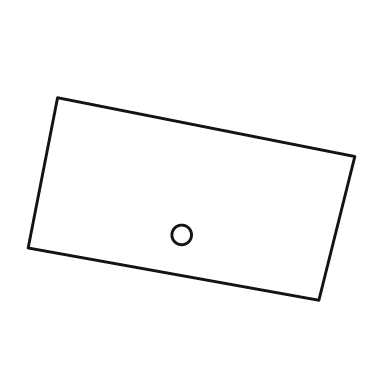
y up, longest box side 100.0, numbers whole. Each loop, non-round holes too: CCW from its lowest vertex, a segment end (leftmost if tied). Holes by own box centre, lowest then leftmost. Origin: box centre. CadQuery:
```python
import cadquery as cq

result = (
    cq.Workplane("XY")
    .moveTo(39.0, -31.0)
    .lineTo(50.0, 13.0)
    .lineTo(-41.0, 31.0)
    .lineTo(-50.0, -15.0)
    .close()
    .moveTo(-3.0, -11.0)
    .circle(3.0)
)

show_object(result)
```